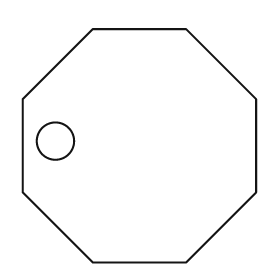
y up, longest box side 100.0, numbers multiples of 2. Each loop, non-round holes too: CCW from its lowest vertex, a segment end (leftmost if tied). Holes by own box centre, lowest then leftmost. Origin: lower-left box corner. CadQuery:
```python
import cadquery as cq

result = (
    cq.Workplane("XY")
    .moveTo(30.0, 0.0)
    .lineTo(70.0, 0.0)
    .lineTo(100.0, 30.0)
    .lineTo(100.0, 70.0)
    .lineTo(70.0, 100.0)
    .lineTo(30.0, 100.0)
    .lineTo(0.0, 70.0)
    .lineTo(0.0, 30.0)
    .close()
    .moveTo(14.0, 52.0)
    .circle(8.0)
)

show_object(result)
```